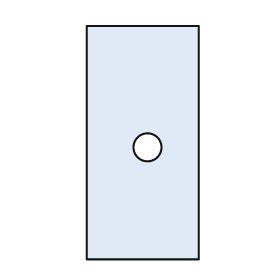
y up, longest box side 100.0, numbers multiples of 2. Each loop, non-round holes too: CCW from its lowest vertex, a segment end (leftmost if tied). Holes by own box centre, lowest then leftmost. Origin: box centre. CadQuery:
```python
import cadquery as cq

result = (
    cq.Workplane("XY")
    .moveTo(-24.0, -50.0)
    .lineTo(24.0, -50.0)
    .lineTo(24.0, 50.0)
    .lineTo(-24.0, 50.0)
    .close()
    .moveTo(2.0, -2.0)
    .circle(6.0)
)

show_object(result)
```